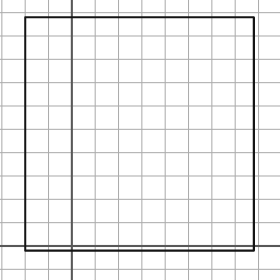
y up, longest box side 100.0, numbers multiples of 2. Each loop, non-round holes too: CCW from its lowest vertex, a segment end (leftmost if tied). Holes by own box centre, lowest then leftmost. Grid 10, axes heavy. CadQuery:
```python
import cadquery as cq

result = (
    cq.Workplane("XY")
    .moveTo(-20.0, -2.0)
    .lineTo(78.0, -2.0)
    .lineTo(78.0, 98.0)
    .lineTo(-20.0, 98.0)
    .close()
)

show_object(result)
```